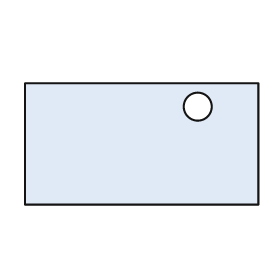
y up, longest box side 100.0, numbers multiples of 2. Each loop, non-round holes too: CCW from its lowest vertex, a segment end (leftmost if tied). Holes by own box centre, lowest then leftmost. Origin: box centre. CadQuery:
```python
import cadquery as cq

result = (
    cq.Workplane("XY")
    .moveTo(-50.0, -26.0)
    .lineTo(50.0, -26.0)
    .lineTo(50.0, 26.0)
    .lineTo(-50.0, 26.0)
    .close()
    .moveTo(24.0, 16.0)
    .circle(6.0)
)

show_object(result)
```